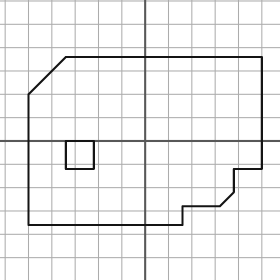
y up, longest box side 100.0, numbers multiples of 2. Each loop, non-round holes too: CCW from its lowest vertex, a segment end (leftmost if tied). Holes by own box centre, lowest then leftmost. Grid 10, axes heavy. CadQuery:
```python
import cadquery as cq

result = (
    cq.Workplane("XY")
    .moveTo(-50.0, -36.0)
    .lineTo(16.0, -36.0)
    .lineTo(16.0, -28.0)
    .lineTo(32.0, -28.0)
    .lineTo(38.0, -22.0)
    .lineTo(38.0, -12.0)
    .lineTo(50.0, -12.0)
    .lineTo(50.0, 36.0)
    .lineTo(-34.0, 36.0)
    .lineTo(-50.0, 20.0)
    .close()
    .moveTo(-34.0, -12.0)
    .lineTo(-22.0, -12.0)
    .lineTo(-22.0, 0.0)
    .lineTo(-34.0, 0.0)
    .close()
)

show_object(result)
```